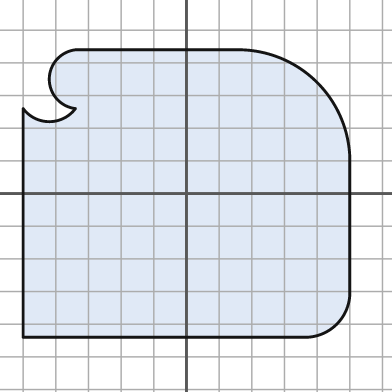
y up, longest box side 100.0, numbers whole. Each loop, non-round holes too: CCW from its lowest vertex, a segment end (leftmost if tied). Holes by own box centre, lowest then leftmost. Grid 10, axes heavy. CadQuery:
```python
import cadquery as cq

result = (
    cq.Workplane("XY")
    .moveTo(-50.0, -44.0)
    .lineTo(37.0, -44.0)
    .threePointArc((46.0, -40.0), (50.0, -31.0))
    .lineTo(50.0, 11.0)
    .threePointArc((40.0, 34.0), (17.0, 44.0))
    .lineTo(-34.0, 44.0)
    .threePointArc((-42.0, 35.0), (-34.0, 26.0))
    .threePointArc((-42.0, 22.0), (-50.0, 26.0))
    .close()
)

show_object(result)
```